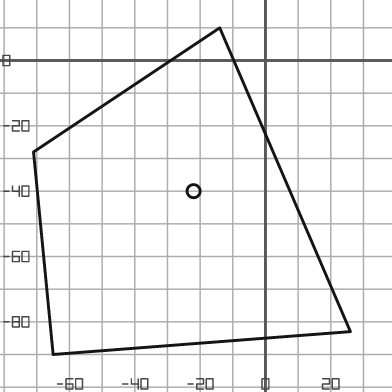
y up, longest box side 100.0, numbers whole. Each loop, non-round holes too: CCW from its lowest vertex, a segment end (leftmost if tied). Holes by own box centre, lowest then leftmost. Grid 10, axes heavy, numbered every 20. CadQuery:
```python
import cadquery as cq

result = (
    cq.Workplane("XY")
    .moveTo(-65.0, -90.0)
    .lineTo(26.0, -83.0)
    .lineTo(-14.0, 10.0)
    .lineTo(-71.0, -28.0)
    .close()
    .moveTo(-22.0, -40.0)
    .circle(2.0)
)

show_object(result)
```